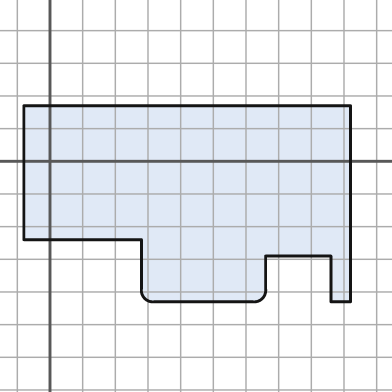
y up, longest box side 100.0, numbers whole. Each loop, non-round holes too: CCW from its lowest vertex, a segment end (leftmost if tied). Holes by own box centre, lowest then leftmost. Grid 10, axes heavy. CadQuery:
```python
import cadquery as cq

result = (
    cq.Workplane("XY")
    .moveTo(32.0, -43.0)
    .lineTo(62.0, -43.0)
    .threePointArc((65.0, -42.0), (66.0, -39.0))
    .lineTo(66.0, -29.0)
    .lineTo(86.0, -29.0)
    .lineTo(86.0, -43.0)
    .lineTo(92.0, -43.0)
    .lineTo(92.0, 17.0)
    .lineTo(-8.0, 17.0)
    .lineTo(-8.0, -24.0)
    .lineTo(28.0, -24.0)
    .lineTo(28.0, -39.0)
    .threePointArc((29.0, -42.0), (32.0, -43.0))
    .close()
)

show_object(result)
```